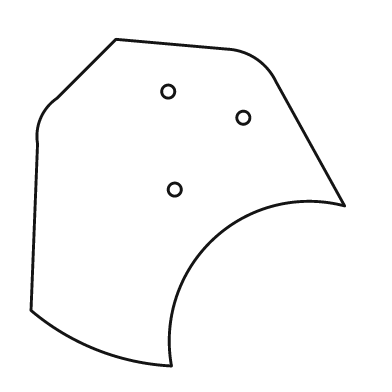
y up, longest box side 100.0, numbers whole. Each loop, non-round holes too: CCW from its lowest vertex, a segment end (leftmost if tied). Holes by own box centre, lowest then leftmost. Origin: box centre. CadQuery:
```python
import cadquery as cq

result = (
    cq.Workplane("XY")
    .moveTo(-5.0, -50.0)
    .threePointArc((8.0, -11.0), (48.0, -1.0))
    .lineTo(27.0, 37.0)
    .threePointArc((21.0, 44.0), (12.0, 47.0))
    .lineTo(-22.0, 50.0)
    .lineTo(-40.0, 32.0)
    .threePointArc((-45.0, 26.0), (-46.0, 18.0))
    .lineTo(-48.0, -33.0)
    .threePointArc((-28.0, -45.0), (-5.0, -50.0))
    .close()
    .moveTo(-4.0, 4.0)
    .circle(2.0)
    .moveTo(17.0, 26.0)
    .circle(2.0)
    .moveTo(-6.0, 34.0)
    .circle(2.0)
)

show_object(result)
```